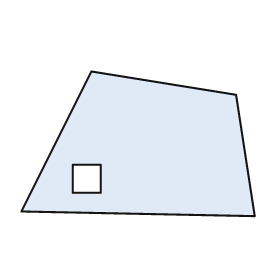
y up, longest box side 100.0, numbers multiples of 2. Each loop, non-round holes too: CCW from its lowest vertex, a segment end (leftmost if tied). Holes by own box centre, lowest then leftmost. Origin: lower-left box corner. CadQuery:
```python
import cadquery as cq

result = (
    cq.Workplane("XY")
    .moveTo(100.0, 0.0)
    .lineTo(92.0, 52.0)
    .lineTo(30.0, 62.0)
    .lineTo(0.0, 2.0)
    .close()
    .moveTo(22.0, 10.0)
    .lineTo(34.0, 10.0)
    .lineTo(34.0, 22.0)
    .lineTo(22.0, 22.0)
    .close()
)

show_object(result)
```